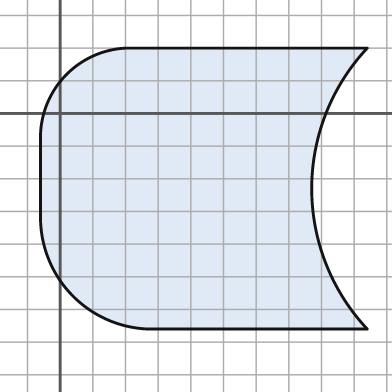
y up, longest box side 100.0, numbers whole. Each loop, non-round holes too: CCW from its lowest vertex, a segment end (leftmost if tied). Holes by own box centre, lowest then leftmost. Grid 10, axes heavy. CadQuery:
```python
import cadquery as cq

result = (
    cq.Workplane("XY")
    .moveTo(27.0, -66.0)
    .lineTo(94.0, -66.0)
    .threePointArc((77.0, -23.0), (94.0, 20.0))
    .lineTo(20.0, 20.0)
    .threePointArc((2.0, 12.0), (-6.0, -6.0))
    .lineTo(-6.0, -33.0)
    .threePointArc((4.0, -56.0), (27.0, -66.0))
    .close()
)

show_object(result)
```